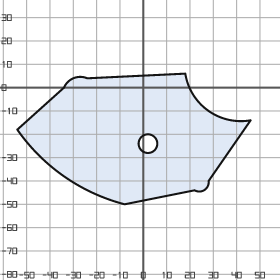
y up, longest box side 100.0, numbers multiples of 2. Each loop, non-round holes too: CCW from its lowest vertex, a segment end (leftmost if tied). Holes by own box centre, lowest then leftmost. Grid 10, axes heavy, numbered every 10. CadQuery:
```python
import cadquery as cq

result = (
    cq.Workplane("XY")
    .moveTo(-8.0, -50.0)
    .lineTo(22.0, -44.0)
    .threePointArc((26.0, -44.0), (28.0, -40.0))
    .lineTo(46.0, -14.0)
    .threePointArc((28.0, -10.0), (18.0, 6.0))
    .lineTo(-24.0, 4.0)
    .threePointArc((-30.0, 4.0), (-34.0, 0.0))
    .lineTo(-54.0, -18.0)
    .threePointArc((-34.0, -38.0), (-8.0, -50.0))
    .close()
    .moveTo(2.0, -24.0)
    .circle(4.0)
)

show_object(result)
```